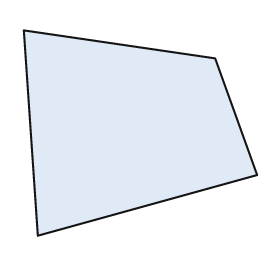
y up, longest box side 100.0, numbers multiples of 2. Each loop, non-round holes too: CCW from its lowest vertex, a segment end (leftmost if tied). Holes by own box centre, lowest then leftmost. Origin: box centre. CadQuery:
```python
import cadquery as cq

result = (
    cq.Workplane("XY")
    .moveTo(-44.0, -44.0)
    .lineTo(50.0, -18.0)
    .lineTo(32.0, 32.0)
    .lineTo(-50.0, 44.0)
    .close()
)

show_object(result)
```